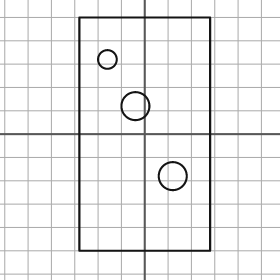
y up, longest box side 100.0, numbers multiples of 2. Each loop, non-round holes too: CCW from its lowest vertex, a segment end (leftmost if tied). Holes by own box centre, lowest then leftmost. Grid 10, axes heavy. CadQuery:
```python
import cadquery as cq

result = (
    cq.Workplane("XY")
    .moveTo(-28.0, -50.0)
    .lineTo(28.0, -50.0)
    .lineTo(28.0, 50.0)
    .lineTo(-28.0, 50.0)
    .close()
    .moveTo(12.0, -18.0)
    .circle(6.0)
    .moveTo(-4.0, 12.0)
    .circle(6.0)
    .moveTo(-16.0, 32.0)
    .circle(4.0)
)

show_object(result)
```